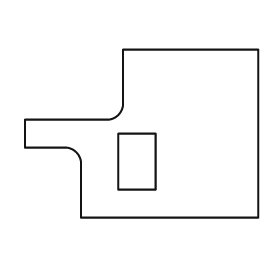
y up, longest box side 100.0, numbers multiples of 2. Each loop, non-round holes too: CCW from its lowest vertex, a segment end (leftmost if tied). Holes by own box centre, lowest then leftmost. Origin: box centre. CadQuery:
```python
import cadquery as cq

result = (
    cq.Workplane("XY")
    .moveTo(-26.0, -36.0)
    .lineTo(50.0, -36.0)
    .lineTo(50.0, 36.0)
    .lineTo(-8.0, 36.0)
    .lineTo(-8.0, 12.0)
    .threePointArc((-10.0, 8.0), (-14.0, 6.0))
    .lineTo(-50.0, 6.0)
    .lineTo(-50.0, -6.0)
    .lineTo(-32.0, -6.0)
    .threePointArc((-28.0, -8.0), (-26.0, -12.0))
    .close()
    .moveTo(-10.0, -24.0)
    .lineTo(6.0, -24.0)
    .lineTo(6.0, 0.0)
    .lineTo(-10.0, 0.0)
    .close()
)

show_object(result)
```